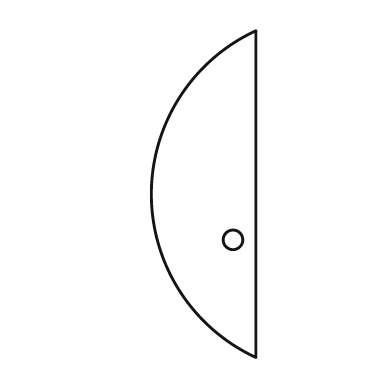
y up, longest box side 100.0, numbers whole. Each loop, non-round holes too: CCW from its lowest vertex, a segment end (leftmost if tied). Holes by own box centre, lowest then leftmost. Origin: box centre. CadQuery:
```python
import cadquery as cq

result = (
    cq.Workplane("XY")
    .moveTo(16.0, -50.0)
    .lineTo(16.0, 50.0)
    .threePointArc((-16.0, 0.0), (16.0, -50.0))
    .close()
    .moveTo(9.0, -14.0)
    .circle(3.0)
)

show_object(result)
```